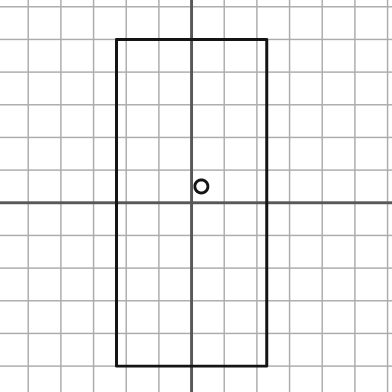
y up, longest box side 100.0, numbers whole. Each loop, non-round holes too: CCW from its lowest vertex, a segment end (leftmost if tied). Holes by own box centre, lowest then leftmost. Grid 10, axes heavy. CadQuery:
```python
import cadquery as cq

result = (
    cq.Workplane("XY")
    .moveTo(-23.0, -50.0)
    .lineTo(23.0, -50.0)
    .lineTo(23.0, 50.0)
    .lineTo(-23.0, 50.0)
    .close()
    .moveTo(3.0, 5.0)
    .circle(2.0)
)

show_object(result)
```